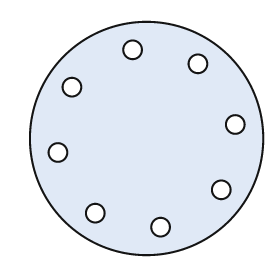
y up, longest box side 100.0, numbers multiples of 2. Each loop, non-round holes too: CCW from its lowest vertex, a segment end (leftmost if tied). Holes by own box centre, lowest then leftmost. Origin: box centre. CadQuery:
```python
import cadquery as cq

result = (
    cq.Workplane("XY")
    .moveTo(0.0, 0.0)
    .circle(50.0)
    .moveTo(6.0, -38.0)
    .circle(4.0)
    .moveTo(-22.0, -32.0)
    .circle(4.0)
    .moveTo(32.0, -22.0)
    .circle(4.0)
    .moveTo(-38.0, -6.0)
    .circle(4.0)
    .moveTo(38.0, 6.0)
    .circle(4.0)
    .moveTo(-32.0, 22.0)
    .circle(4.0)
    .moveTo(22.0, 32.0)
    .circle(4.0)
    .moveTo(-6.0, 38.0)
    .circle(4.0)
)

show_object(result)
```